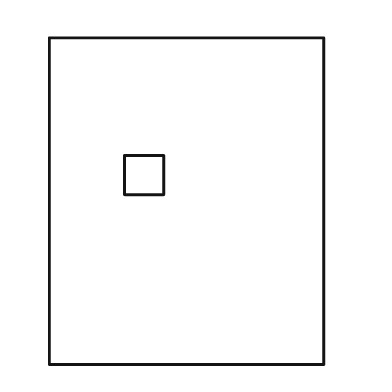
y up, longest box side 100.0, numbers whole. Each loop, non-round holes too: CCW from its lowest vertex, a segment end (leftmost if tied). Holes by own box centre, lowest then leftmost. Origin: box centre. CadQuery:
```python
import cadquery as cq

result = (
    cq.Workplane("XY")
    .moveTo(-42.0, -50.0)
    .lineTo(42.0, -50.0)
    .lineTo(42.0, 50.0)
    .lineTo(-42.0, 50.0)
    .close()
    .moveTo(-19.0, 2.0)
    .lineTo(-7.0, 2.0)
    .lineTo(-7.0, 14.0)
    .lineTo(-19.0, 14.0)
    .close()
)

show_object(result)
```